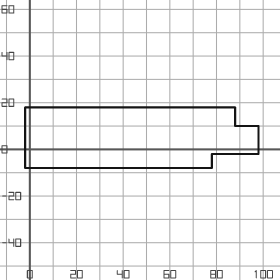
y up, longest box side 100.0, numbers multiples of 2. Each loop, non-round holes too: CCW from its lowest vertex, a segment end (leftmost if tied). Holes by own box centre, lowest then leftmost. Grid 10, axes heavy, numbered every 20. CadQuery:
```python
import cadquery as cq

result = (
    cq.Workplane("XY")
    .moveTo(-2.0, -8.0)
    .lineTo(78.0, -8.0)
    .lineTo(78.0, -2.0)
    .lineTo(98.0, -2.0)
    .lineTo(98.0, 10.0)
    .lineTo(88.0, 10.0)
    .lineTo(88.0, 18.0)
    .lineTo(-2.0, 18.0)
    .close()
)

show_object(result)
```